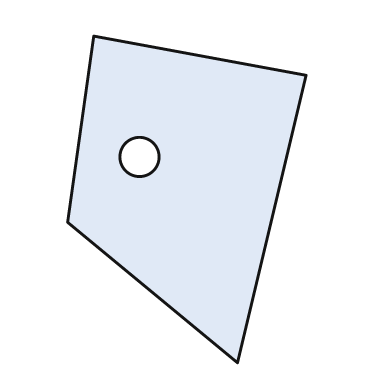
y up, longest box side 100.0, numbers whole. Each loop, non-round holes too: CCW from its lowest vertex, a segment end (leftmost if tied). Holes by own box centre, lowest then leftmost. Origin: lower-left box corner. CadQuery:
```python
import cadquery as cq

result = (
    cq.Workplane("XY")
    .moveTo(52.0, 0.0)
    .lineTo(73.0, 88.0)
    .lineTo(8.0, 100.0)
    .lineTo(0.0, 43.0)
    .close()
    .moveTo(22.0, 63.0)
    .circle(6.0)
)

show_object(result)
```